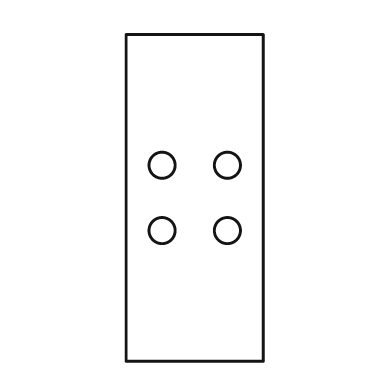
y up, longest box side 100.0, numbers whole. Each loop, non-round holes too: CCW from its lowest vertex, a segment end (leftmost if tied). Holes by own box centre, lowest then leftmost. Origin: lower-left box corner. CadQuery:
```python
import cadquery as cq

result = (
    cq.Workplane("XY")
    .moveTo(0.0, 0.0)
    .lineTo(42.0, 0.0)
    .lineTo(42.0, 100.0)
    .lineTo(0.0, 100.0)
    .close()
    .moveTo(11.0, 40.0)
    .circle(4.0)
    .moveTo(31.0, 40.0)
    .circle(4.0)
    .moveTo(11.0, 60.0)
    .circle(4.0)
    .moveTo(31.0, 60.0)
    .circle(4.0)
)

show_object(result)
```